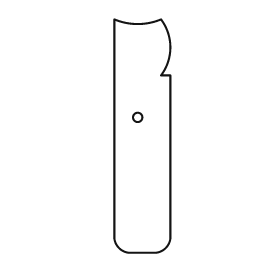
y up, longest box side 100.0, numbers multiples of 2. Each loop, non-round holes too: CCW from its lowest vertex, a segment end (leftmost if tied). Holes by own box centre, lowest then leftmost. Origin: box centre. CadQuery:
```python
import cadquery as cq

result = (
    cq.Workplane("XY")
    .moveTo(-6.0, -50.0)
    .lineTo(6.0, -50.0)
    .threePointArc((10.0, -48.0), (12.0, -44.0))
    .lineTo(12.0, 26.0)
    .lineTo(8.0, 26.0)
    .threePointArc((12.0, 38.0), (8.0, 50.0))
    .threePointArc((-2.0, 48.0), (-12.0, 50.0))
    .lineTo(-12.0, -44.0)
    .threePointArc((-10.0, -48.0), (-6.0, -50.0))
    .close()
    .moveTo(-2.0, 8.0)
    .circle(2.0)
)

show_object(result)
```